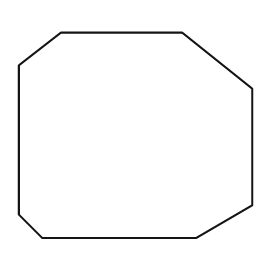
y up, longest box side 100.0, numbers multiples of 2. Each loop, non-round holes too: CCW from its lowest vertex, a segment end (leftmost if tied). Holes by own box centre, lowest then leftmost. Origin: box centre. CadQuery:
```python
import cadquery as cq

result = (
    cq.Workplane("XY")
    .moveTo(-40.0, -44.0)
    .lineTo(26.0, -44.0)
    .lineTo(50.0, -30.0)
    .lineTo(50.0, 20.0)
    .lineTo(20.0, 44.0)
    .lineTo(-32.0, 44.0)
    .lineTo(-50.0, 30.0)
    .lineTo(-50.0, -34.0)
    .close()
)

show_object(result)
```